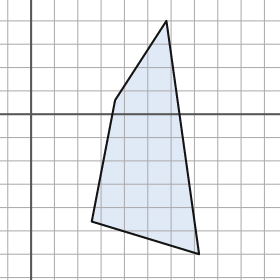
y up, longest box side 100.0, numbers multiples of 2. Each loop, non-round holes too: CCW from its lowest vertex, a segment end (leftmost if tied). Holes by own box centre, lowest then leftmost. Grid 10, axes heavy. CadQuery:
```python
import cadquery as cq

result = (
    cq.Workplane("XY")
    .moveTo(72.0, -60.0)
    .lineTo(58.0, 40.0)
    .lineTo(36.0, 6.0)
    .lineTo(26.0, -46.0)
    .close()
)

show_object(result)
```